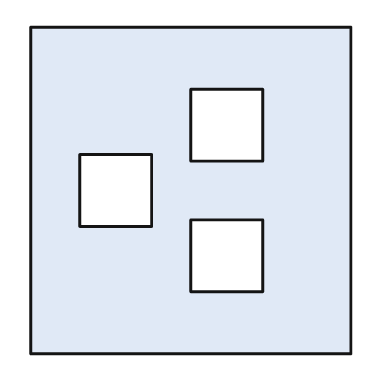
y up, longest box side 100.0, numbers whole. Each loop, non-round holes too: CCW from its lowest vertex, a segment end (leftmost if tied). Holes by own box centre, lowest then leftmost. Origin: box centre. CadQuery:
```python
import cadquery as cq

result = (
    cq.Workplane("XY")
    .moveTo(-49.0, -50.0)
    .lineTo(49.0, -50.0)
    .lineTo(49.0, 50.0)
    .lineTo(-49.0, 50.0)
    .close()
    .moveTo(0.0, -31.0)
    .lineTo(22.0, -31.0)
    .lineTo(22.0, -9.0)
    .lineTo(0.0, -9.0)
    .close()
    .moveTo(-34.0, -11.0)
    .lineTo(-12.0, -11.0)
    .lineTo(-12.0, 11.0)
    .lineTo(-34.0, 11.0)
    .close()
    .moveTo(0.0, 9.0)
    .lineTo(22.0, 9.0)
    .lineTo(22.0, 31.0)
    .lineTo(0.0, 31.0)
    .close()
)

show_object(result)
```